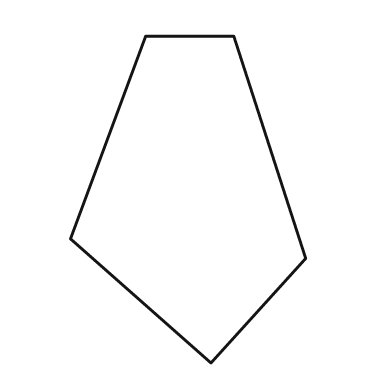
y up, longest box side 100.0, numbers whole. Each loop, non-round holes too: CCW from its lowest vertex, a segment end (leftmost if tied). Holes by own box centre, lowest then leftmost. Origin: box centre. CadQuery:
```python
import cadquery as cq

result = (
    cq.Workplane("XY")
    .moveTo(7.0, -50.0)
    .lineTo(36.0, -18.0)
    .lineTo(14.0, 50.0)
    .lineTo(-13.0, 50.0)
    .lineTo(-36.0, -12.0)
    .close()
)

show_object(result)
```